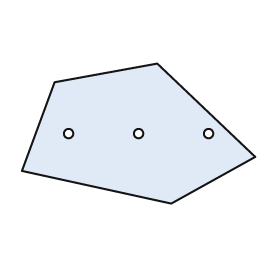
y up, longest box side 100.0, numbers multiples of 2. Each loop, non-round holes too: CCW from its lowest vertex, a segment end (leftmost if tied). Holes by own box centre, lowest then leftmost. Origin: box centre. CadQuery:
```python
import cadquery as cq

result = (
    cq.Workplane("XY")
    .moveTo(14.0, -30.0)
    .lineTo(50.0, -10.0)
    .lineTo(8.0, 30.0)
    .lineTo(-36.0, 22.0)
    .lineTo(-50.0, -16.0)
    .close()
    .moveTo(-30.0, 0.0)
    .circle(2.0)
    .moveTo(0.0, 0.0)
    .circle(2.0)
    .moveTo(30.0, 0.0)
    .circle(2.0)
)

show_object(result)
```